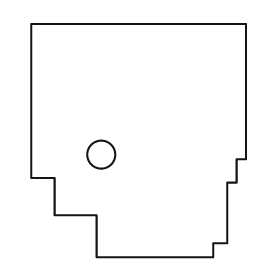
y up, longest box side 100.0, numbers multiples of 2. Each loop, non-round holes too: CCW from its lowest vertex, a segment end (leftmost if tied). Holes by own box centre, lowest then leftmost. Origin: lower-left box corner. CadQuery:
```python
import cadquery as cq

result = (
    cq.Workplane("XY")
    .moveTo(28.0, 0.0)
    .lineTo(78.0, 0.0)
    .lineTo(78.0, 6.0)
    .lineTo(84.0, 6.0)
    .lineTo(84.0, 32.0)
    .lineTo(88.0, 32.0)
    .lineTo(88.0, 42.0)
    .lineTo(92.0, 42.0)
    .lineTo(92.0, 100.0)
    .lineTo(0.0, 100.0)
    .lineTo(0.0, 34.0)
    .lineTo(10.0, 34.0)
    .lineTo(10.0, 18.0)
    .lineTo(28.0, 18.0)
    .close()
    .moveTo(30.0, 44.0)
    .circle(6.0)
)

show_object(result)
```